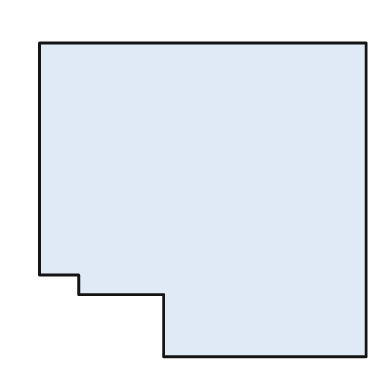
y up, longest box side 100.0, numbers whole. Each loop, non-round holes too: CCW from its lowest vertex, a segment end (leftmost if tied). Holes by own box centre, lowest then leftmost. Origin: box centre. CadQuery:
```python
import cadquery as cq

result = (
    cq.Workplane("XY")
    .moveTo(-12.0, -48.0)
    .lineTo(50.0, -48.0)
    .lineTo(50.0, 48.0)
    .lineTo(-50.0, 48.0)
    .lineTo(-50.0, -23.0)
    .lineTo(-38.0, -23.0)
    .lineTo(-38.0, -29.0)
    .lineTo(-12.0, -29.0)
    .close()
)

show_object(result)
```